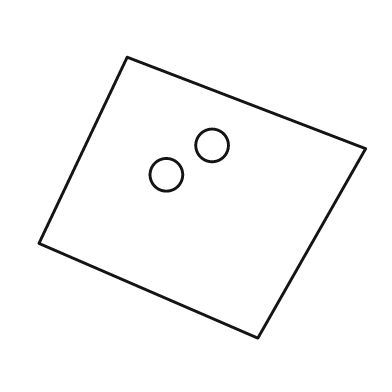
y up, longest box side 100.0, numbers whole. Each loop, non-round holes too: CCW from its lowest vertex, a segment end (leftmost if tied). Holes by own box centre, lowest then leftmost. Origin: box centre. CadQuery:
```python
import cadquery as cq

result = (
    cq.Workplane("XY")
    .moveTo(17.0, -43.0)
    .lineTo(50.0, 15.0)
    .lineTo(-23.0, 43.0)
    .lineTo(-50.0, -14.0)
    .close()
    .moveTo(-11.0, 7.0)
    .circle(5.0)
    .moveTo(3.0, 16.0)
    .circle(5.0)
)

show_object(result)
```